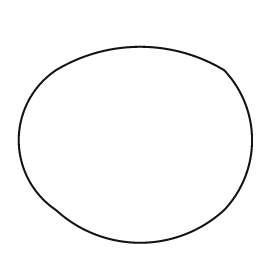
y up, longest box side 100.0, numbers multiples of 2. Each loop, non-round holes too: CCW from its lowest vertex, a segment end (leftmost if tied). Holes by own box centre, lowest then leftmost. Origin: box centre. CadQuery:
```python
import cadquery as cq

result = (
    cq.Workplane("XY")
    .moveTo(-34.0, -28.0)
    .threePointArc((2.0, -42.0), (38.0, -28.0))
    .threePointArc((50.0, 2.0), (38.0, 32.0))
    .threePointArc((2.0, 42.0), (-34.0, 32.0))
    .threePointArc((-50.0, 2.0), (-34.0, -28.0))
    .close()
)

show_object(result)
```